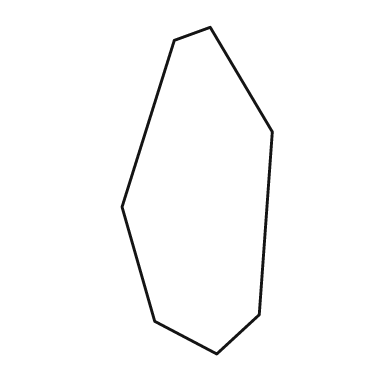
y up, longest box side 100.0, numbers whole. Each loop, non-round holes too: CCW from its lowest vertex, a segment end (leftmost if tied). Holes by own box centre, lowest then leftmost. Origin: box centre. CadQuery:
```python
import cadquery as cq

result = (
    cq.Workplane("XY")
    .moveTo(6.0, -50.0)
    .lineTo(19.0, -38.0)
    .lineTo(23.0, 18.0)
    .lineTo(4.0, 50.0)
    .lineTo(-7.0, 46.0)
    .lineTo(-23.0, -5.0)
    .lineTo(-13.0, -40.0)
    .close()
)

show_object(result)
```